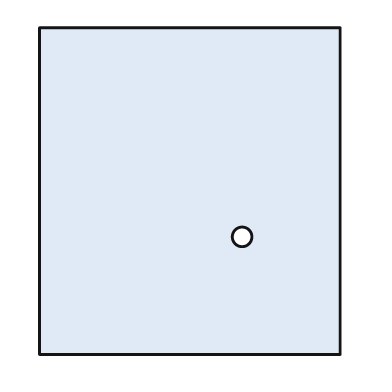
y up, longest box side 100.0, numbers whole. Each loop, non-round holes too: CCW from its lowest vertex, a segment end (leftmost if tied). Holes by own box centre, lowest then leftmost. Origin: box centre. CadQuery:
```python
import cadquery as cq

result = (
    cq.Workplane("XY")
    .moveTo(-46.0, -50.0)
    .lineTo(46.0, -50.0)
    .lineTo(46.0, 50.0)
    .lineTo(-46.0, 50.0)
    .close()
    .moveTo(16.0, -14.0)
    .circle(3.0)
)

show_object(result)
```